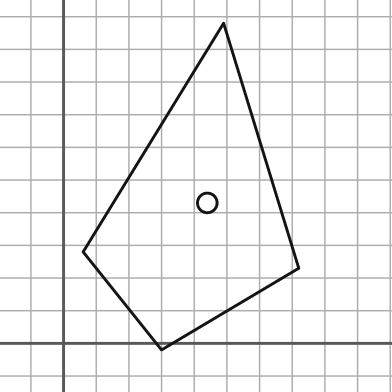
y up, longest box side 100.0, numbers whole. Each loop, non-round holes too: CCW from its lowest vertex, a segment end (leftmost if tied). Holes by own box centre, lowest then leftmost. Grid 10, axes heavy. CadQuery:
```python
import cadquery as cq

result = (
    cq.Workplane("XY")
    .moveTo(30.0, -2.0)
    .lineTo(72.0, 23.0)
    .lineTo(49.0, 98.0)
    .lineTo(6.0, 28.0)
    .close()
    .moveTo(44.0, 43.0)
    .circle(3.0)
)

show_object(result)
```